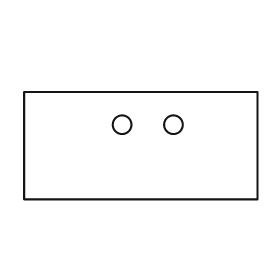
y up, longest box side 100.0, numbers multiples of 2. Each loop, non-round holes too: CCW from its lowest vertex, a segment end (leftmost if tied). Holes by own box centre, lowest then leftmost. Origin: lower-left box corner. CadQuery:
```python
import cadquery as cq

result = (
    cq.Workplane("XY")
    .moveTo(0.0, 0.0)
    .lineTo(100.0, 0.0)
    .lineTo(100.0, 46.0)
    .lineTo(0.0, 46.0)
    .close()
    .moveTo(42.0, 32.0)
    .circle(4.0)
    .moveTo(64.0, 32.0)
    .circle(4.0)
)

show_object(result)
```